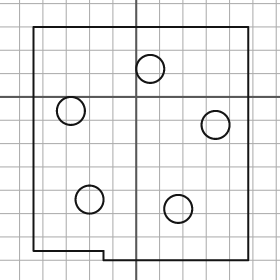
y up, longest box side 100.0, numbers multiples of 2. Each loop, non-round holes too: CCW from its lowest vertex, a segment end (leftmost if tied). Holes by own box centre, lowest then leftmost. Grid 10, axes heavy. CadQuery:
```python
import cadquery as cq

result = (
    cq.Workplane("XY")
    .moveTo(-14.0, -70.0)
    .lineTo(48.0, -70.0)
    .lineTo(48.0, 30.0)
    .lineTo(-44.0, 30.0)
    .lineTo(-44.0, -66.0)
    .lineTo(-14.0, -66.0)
    .close()
    .moveTo(18.0, -48.0)
    .circle(6.0)
    .moveTo(-20.0, -44.0)
    .circle(6.0)
    .moveTo(34.0, -12.0)
    .circle(6.0)
    .moveTo(-28.0, -6.0)
    .circle(6.0)
    .moveTo(6.0, 12.0)
    .circle(6.0)
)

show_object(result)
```